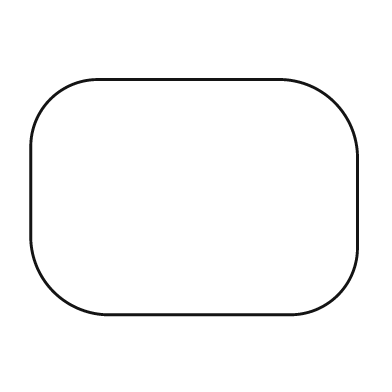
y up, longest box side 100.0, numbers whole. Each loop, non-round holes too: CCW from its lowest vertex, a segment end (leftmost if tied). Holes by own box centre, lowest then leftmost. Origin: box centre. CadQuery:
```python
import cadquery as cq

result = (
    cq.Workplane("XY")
    .moveTo(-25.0, -36.0)
    .lineTo(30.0, -36.0)
    .threePointArc((44.0, -30.0), (50.0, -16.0))
    .lineTo(50.0, 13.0)
    .threePointArc((43.0, 29.0), (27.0, 36.0))
    .lineTo(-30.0, 36.0)
    .threePointArc((-44.0, 30.0), (-50.0, 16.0))
    .lineTo(-50.0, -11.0)
    .threePointArc((-43.0, -29.0), (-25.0, -36.0))
    .close()
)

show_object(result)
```